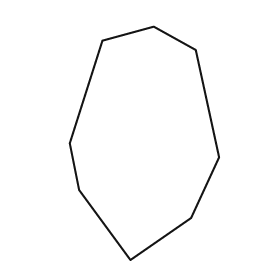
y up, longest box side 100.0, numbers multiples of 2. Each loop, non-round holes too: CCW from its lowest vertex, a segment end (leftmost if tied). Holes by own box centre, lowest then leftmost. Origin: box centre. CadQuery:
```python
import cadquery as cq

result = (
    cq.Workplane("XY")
    .moveTo(-6.0, -50.0)
    .lineTo(20.0, -32.0)
    .lineTo(32.0, -6.0)
    .lineTo(22.0, 40.0)
    .lineTo(4.0, 50.0)
    .lineTo(-18.0, 44.0)
    .lineTo(-32.0, 0.0)
    .lineTo(-28.0, -20.0)
    .close()
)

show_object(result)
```